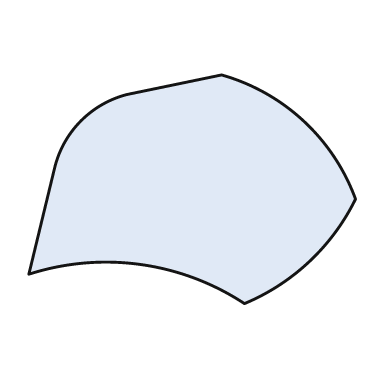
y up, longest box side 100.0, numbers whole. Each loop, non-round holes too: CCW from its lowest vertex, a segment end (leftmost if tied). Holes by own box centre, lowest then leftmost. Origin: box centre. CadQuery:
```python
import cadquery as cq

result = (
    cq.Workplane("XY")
    .moveTo(16.0, -35.0)
    .threePointArc((36.0, -22.0), (50.0, -3.0))
    .threePointArc((34.0, 21.0), (9.0, 35.0))
    .lineTo(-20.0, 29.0)
    .threePointArc((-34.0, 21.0), (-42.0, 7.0))
    .lineTo(-50.0, -26.0)
    .threePointArc((-16.0, -23.0), (16.0, -35.0))
    .close()
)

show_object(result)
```